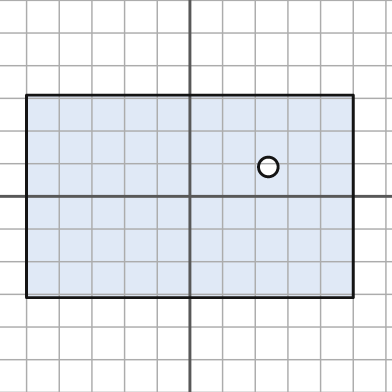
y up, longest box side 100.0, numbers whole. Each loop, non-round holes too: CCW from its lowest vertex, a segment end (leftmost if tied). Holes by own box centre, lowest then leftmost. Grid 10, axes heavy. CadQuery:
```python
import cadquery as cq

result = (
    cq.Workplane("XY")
    .moveTo(-50.0, -31.0)
    .lineTo(50.0, -31.0)
    .lineTo(50.0, 31.0)
    .lineTo(-50.0, 31.0)
    .close()
    .moveTo(24.0, 9.0)
    .circle(3.0)
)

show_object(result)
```